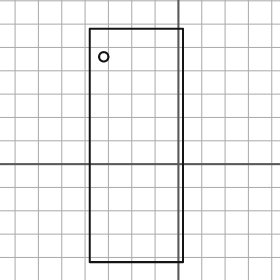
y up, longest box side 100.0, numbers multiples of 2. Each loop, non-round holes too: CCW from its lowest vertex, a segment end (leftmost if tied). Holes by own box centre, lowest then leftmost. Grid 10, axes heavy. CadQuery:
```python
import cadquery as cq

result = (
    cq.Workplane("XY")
    .moveTo(-38.0, -42.0)
    .lineTo(2.0, -42.0)
    .lineTo(2.0, 58.0)
    .lineTo(-38.0, 58.0)
    .close()
    .moveTo(-32.0, 46.0)
    .circle(2.0)
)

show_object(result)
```